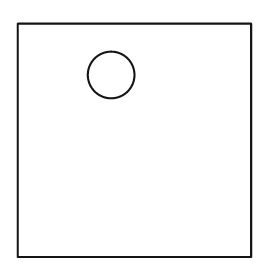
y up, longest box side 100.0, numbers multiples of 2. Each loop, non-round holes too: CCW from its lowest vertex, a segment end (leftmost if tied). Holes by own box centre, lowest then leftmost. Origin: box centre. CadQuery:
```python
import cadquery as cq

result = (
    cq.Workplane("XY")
    .moveTo(-50.0, -50.0)
    .lineTo(50.0, -50.0)
    .lineTo(50.0, 50.0)
    .lineTo(-50.0, 50.0)
    .close()
    .moveTo(-10.0, 28.0)
    .circle(10.0)
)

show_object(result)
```